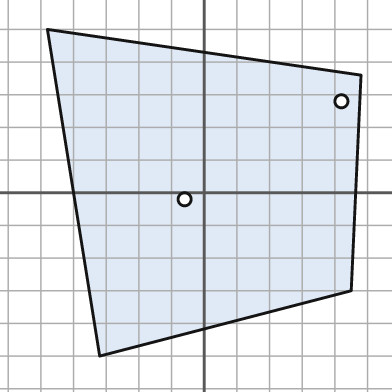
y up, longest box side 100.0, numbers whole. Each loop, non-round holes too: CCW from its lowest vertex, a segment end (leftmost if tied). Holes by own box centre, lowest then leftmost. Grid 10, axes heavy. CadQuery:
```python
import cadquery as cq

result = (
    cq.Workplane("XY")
    .moveTo(-32.0, -50.0)
    .lineTo(45.0, -30.0)
    .lineTo(48.0, 36.0)
    .lineTo(-48.0, 50.0)
    .close()
    .moveTo(-6.0, -2.0)
    .circle(2.0)
    .moveTo(42.0, 28.0)
    .circle(2.0)
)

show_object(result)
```